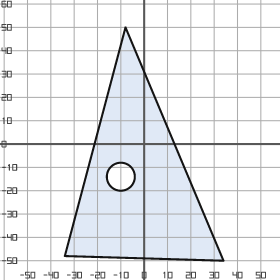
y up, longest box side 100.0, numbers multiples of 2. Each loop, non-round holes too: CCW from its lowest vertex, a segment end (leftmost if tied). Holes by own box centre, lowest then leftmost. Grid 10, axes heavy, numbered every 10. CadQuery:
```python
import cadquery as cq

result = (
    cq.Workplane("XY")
    .moveTo(34.0, -50.0)
    .lineTo(-8.0, 50.0)
    .lineTo(-34.0, -48.0)
    .close()
    .moveTo(-10.0, -14.0)
    .circle(6.0)
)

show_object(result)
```